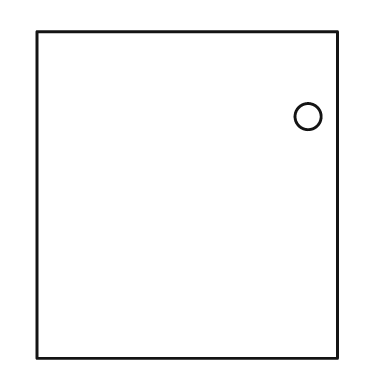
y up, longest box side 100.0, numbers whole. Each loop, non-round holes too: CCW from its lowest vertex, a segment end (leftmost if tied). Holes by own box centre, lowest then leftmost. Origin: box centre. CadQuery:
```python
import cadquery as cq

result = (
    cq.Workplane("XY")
    .moveTo(-46.0, -50.0)
    .lineTo(46.0, -50.0)
    .lineTo(46.0, 50.0)
    .lineTo(-46.0, 50.0)
    .close()
    .moveTo(37.0, 24.0)
    .circle(4.0)
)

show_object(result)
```